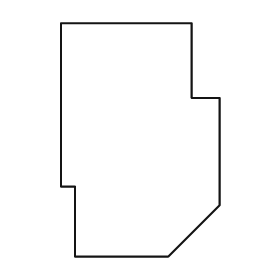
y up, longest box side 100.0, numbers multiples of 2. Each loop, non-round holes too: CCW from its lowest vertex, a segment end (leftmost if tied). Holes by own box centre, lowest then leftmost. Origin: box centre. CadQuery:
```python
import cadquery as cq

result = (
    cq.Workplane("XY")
    .moveTo(-28.0, -50.0)
    .lineTo(12.0, -50.0)
    .lineTo(34.0, -28.0)
    .lineTo(34.0, 18.0)
    .lineTo(22.0, 18.0)
    .lineTo(22.0, 50.0)
    .lineTo(-34.0, 50.0)
    .lineTo(-34.0, -20.0)
    .lineTo(-28.0, -20.0)
    .close()
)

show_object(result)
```